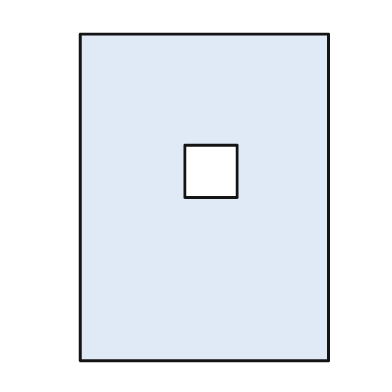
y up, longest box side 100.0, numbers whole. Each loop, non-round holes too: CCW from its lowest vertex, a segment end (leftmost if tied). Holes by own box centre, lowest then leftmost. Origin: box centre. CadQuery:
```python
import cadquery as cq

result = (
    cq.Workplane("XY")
    .moveTo(-38.0, -50.0)
    .lineTo(38.0, -50.0)
    .lineTo(38.0, 50.0)
    .lineTo(-38.0, 50.0)
    .close()
    .moveTo(-6.0, 0.0)
    .lineTo(10.0, 0.0)
    .lineTo(10.0, 16.0)
    .lineTo(-6.0, 16.0)
    .close()
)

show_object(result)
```